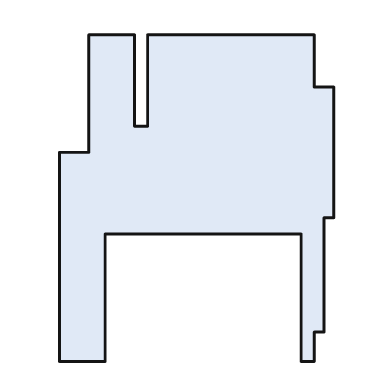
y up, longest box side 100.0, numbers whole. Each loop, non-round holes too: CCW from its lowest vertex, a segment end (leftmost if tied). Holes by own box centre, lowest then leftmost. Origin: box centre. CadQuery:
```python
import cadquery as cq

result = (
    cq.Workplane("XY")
    .moveTo(-42.0, -50.0)
    .lineTo(-28.0, -50.0)
    .lineTo(-28.0, -11.0)
    .lineTo(32.0, -11.0)
    .lineTo(32.0, -50.0)
    .lineTo(36.0, -50.0)
    .lineTo(36.0, -41.0)
    .lineTo(39.0, -41.0)
    .lineTo(39.0, -6.0)
    .lineTo(42.0, -6.0)
    .lineTo(42.0, 34.0)
    .lineTo(36.0, 34.0)
    .lineTo(36.0, 50.0)
    .lineTo(-15.0, 50.0)
    .lineTo(-15.0, 22.0)
    .lineTo(-19.0, 22.0)
    .lineTo(-19.0, 50.0)
    .lineTo(-33.0, 50.0)
    .lineTo(-33.0, 14.0)
    .lineTo(-42.0, 14.0)
    .close()
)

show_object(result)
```